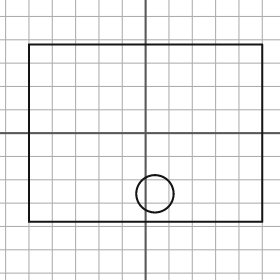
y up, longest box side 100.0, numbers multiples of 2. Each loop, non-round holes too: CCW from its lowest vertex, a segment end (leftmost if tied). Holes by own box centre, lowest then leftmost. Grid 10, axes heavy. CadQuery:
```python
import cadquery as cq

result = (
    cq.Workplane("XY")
    .moveTo(-50.0, -38.0)
    .lineTo(50.0, -38.0)
    .lineTo(50.0, 38.0)
    .lineTo(-50.0, 38.0)
    .close()
    .moveTo(4.0, -26.0)
    .circle(8.0)
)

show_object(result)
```